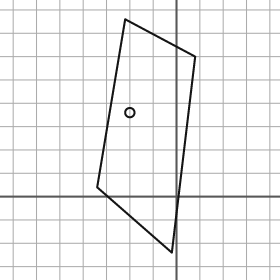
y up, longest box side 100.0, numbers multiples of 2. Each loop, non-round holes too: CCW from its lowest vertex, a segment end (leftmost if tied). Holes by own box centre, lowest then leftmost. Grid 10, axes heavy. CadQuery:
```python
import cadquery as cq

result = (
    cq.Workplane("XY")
    .moveTo(-2.0, -24.0)
    .lineTo(8.0, 60.0)
    .lineTo(-22.0, 76.0)
    .lineTo(-34.0, 4.0)
    .close()
    .moveTo(-20.0, 36.0)
    .circle(2.0)
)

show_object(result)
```